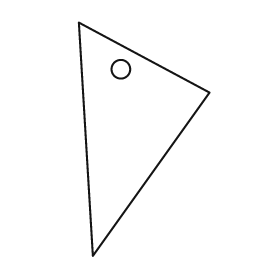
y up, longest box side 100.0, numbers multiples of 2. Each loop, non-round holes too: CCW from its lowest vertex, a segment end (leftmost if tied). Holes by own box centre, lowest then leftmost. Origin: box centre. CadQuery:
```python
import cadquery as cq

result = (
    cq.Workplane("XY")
    .moveTo(-22.0, -50.0)
    .lineTo(28.0, 20.0)
    .lineTo(-28.0, 50.0)
    .close()
    .moveTo(-10.0, 30.0)
    .circle(4.0)
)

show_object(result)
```